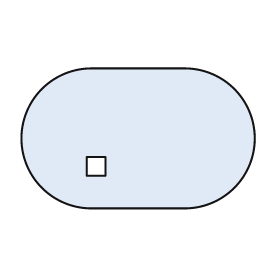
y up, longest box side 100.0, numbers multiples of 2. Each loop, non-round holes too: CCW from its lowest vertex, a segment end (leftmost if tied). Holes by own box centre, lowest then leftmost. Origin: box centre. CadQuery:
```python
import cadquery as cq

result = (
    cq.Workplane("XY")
    .moveTo(-20.0, -30.0)
    .lineTo(20.0, -30.0)
    .threePointArc((50.0, 0.0), (20.0, 30.0))
    .lineTo(-20.0, 30.0)
    .threePointArc((-50.0, 0.0), (-20.0, -30.0))
    .close()
    .moveTo(-22.0, -16.0)
    .lineTo(-14.0, -16.0)
    .lineTo(-14.0, -8.0)
    .lineTo(-22.0, -8.0)
    .close()
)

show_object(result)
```